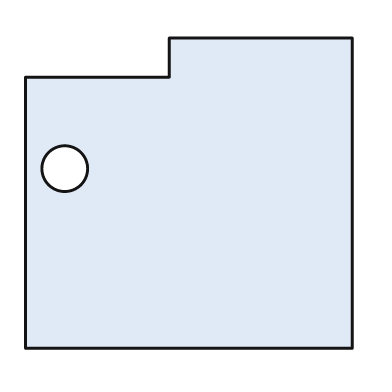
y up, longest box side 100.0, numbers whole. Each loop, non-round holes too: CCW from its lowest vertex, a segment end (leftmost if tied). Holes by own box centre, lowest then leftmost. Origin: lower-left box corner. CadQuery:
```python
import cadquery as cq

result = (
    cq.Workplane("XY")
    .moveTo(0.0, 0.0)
    .lineTo(100.0, 0.0)
    .lineTo(100.0, 95.0)
    .lineTo(44.0, 95.0)
    .lineTo(44.0, 83.0)
    .lineTo(0.0, 83.0)
    .close()
    .moveTo(12.0, 55.0)
    .circle(7.0)
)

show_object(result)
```